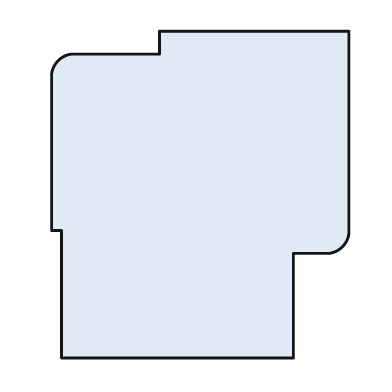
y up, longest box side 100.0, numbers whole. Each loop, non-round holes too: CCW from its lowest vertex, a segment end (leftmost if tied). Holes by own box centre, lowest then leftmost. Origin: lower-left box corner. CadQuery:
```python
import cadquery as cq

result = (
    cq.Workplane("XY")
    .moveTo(3.0, 0.0)
    .lineTo(74.0, 0.0)
    .lineTo(74.0, 32.0)
    .lineTo(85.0, 32.0)
    .threePointArc((89.0, 34.0), (91.0, 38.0))
    .lineTo(91.0, 100.0)
    .lineTo(33.0, 100.0)
    .lineTo(33.0, 93.0)
    .lineTo(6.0, 93.0)
    .threePointArc((2.0, 91.0), (0.0, 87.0))
    .lineTo(0.0, 39.0)
    .lineTo(3.0, 39.0)
    .close()
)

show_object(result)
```